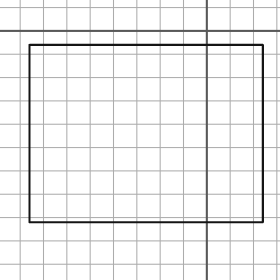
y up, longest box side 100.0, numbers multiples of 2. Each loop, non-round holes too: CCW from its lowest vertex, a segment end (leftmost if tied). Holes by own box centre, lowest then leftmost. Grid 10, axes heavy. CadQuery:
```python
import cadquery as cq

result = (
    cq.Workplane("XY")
    .moveTo(-76.0, -82.0)
    .lineTo(24.0, -82.0)
    .lineTo(24.0, -6.0)
    .lineTo(-76.0, -6.0)
    .close()
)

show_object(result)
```